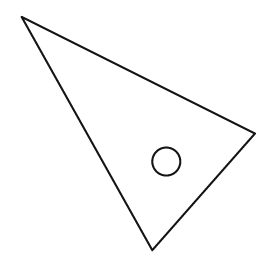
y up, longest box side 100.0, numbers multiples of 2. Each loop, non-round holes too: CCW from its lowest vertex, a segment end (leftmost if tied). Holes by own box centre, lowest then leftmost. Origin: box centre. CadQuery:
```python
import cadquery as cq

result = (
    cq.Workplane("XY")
    .moveTo(6.0, -50.0)
    .lineTo(50.0, 0.0)
    .lineTo(-50.0, 50.0)
    .close()
    .moveTo(12.0, -12.0)
    .circle(6.0)
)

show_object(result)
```